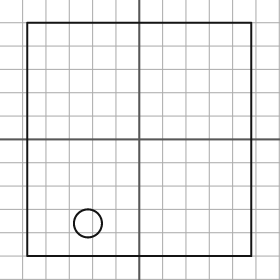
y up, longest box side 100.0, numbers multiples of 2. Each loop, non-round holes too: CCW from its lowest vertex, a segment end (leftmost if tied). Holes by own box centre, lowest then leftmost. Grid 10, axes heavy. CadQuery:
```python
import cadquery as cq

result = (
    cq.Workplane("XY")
    .moveTo(-48.0, -50.0)
    .lineTo(48.0, -50.0)
    .lineTo(48.0, 50.0)
    .lineTo(-48.0, 50.0)
    .close()
    .moveTo(-22.0, -36.0)
    .circle(6.0)
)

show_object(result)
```